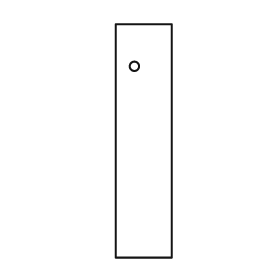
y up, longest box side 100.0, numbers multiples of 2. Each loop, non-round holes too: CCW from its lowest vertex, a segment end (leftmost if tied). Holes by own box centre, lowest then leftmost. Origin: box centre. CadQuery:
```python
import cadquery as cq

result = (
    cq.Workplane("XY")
    .moveTo(-12.0, -50.0)
    .lineTo(12.0, -50.0)
    .lineTo(12.0, 50.0)
    .lineTo(-12.0, 50.0)
    .close()
    .moveTo(-4.0, 32.0)
    .circle(2.0)
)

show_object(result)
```